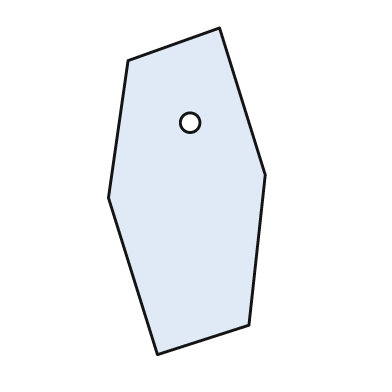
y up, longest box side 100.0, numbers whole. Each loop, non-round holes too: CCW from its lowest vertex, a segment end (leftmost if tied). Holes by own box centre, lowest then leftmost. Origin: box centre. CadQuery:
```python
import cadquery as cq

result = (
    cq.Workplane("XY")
    .moveTo(-9.0, -50.0)
    .lineTo(19.0, -41.0)
    .lineTo(24.0, 5.0)
    .lineTo(10.0, 50.0)
    .lineTo(-18.0, 40.0)
    .lineTo(-24.0, -2.0)
    .close()
    .moveTo(1.0, 21.0)
    .circle(3.0)
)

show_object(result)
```